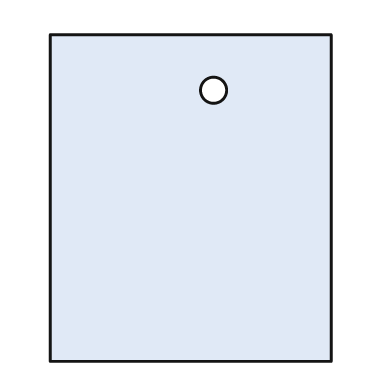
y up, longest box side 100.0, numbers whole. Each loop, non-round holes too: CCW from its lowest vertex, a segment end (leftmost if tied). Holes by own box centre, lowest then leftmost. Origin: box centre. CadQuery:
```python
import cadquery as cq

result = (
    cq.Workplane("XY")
    .moveTo(-43.0, -50.0)
    .lineTo(43.0, -50.0)
    .lineTo(43.0, 50.0)
    .lineTo(-43.0, 50.0)
    .close()
    .moveTo(7.0, 33.0)
    .circle(4.0)
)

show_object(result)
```